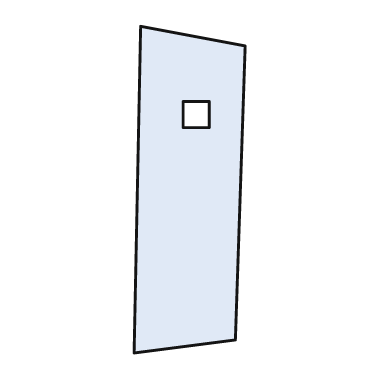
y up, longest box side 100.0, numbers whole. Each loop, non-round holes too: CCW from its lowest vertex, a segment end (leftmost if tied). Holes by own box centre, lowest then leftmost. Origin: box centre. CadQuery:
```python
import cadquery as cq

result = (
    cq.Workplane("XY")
    .moveTo(-17.0, -50.0)
    .lineTo(14.0, -46.0)
    .lineTo(17.0, 44.0)
    .lineTo(-15.0, 50.0)
    .close()
    .moveTo(-2.0, 19.0)
    .lineTo(6.0, 19.0)
    .lineTo(6.0, 27.0)
    .lineTo(-2.0, 27.0)
    .close()
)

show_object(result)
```